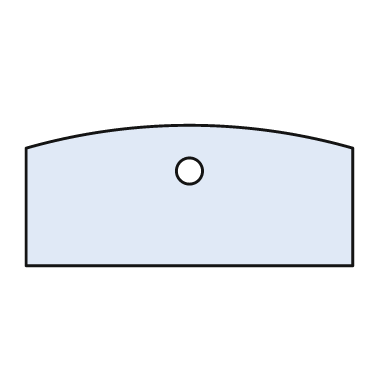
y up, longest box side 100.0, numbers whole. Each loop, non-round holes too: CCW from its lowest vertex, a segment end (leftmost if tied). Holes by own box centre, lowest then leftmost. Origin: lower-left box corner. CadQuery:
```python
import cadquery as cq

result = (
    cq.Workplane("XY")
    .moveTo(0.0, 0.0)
    .lineTo(100.0, 0.0)
    .lineTo(100.0, 36.0)
    .threePointArc((50.0, 43.0), (0.0, 36.0))
    .close()
    .moveTo(50.0, 29.0)
    .circle(4.0)
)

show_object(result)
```